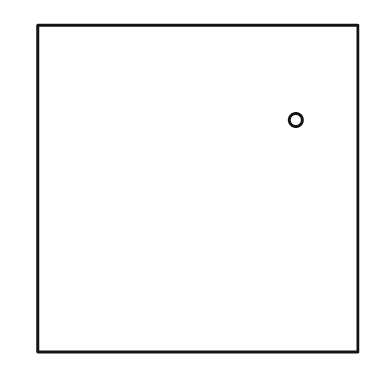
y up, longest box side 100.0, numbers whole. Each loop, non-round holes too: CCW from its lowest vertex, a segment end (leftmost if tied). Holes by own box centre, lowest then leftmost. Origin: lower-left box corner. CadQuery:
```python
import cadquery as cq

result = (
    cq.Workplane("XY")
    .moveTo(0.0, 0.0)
    .lineTo(98.0, 0.0)
    .lineTo(98.0, 100.0)
    .lineTo(0.0, 100.0)
    .close()
    .moveTo(79.0, 71.0)
    .circle(2.0)
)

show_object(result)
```